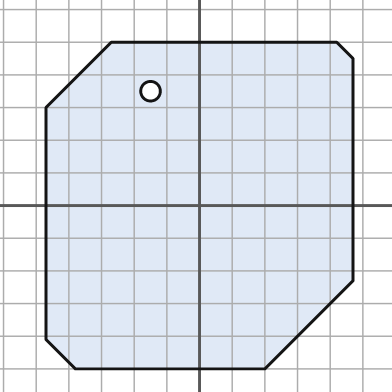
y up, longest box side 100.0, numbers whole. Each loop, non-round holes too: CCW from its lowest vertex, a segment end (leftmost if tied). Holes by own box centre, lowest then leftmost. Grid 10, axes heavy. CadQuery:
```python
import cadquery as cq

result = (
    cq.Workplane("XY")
    .moveTo(-38.0, -50.0)
    .lineTo(20.0, -50.0)
    .lineTo(47.0, -23.0)
    .lineTo(47.0, 45.0)
    .lineTo(42.0, 50.0)
    .lineTo(-27.0, 50.0)
    .lineTo(-47.0, 30.0)
    .lineTo(-47.0, -41.0)
    .close()
    .moveTo(-15.0, 35.0)
    .circle(3.0)
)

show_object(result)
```